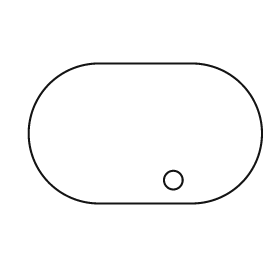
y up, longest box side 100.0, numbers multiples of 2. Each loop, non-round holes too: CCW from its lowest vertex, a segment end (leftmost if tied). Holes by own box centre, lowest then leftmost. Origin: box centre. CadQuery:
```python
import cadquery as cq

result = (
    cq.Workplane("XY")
    .moveTo(-20.0, -30.0)
    .lineTo(20.0, -30.0)
    .threePointArc((50.0, 0.0), (20.0, 30.0))
    .lineTo(-20.0, 30.0)
    .threePointArc((-50.0, 0.0), (-20.0, -30.0))
    .close()
    .moveTo(12.0, -20.0)
    .circle(4.0)
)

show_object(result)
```